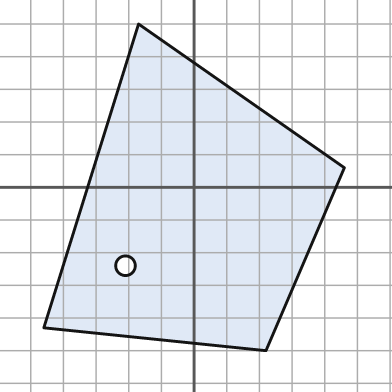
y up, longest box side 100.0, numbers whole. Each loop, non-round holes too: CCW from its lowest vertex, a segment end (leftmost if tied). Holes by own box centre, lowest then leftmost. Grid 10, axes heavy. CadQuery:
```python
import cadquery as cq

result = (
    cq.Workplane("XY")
    .moveTo(22.0, -50.0)
    .lineTo(46.0, 6.0)
    .lineTo(-17.0, 50.0)
    .lineTo(-46.0, -43.0)
    .close()
    .moveTo(-21.0, -24.0)
    .circle(3.0)
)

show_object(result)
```